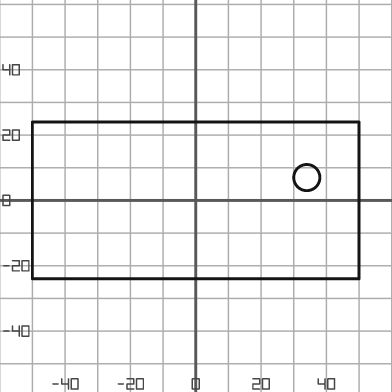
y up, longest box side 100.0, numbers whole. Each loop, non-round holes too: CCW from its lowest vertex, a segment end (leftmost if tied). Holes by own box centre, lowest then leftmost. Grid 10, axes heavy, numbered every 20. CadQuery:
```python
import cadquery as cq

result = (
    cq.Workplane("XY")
    .moveTo(-50.0, -24.0)
    .lineTo(50.0, -24.0)
    .lineTo(50.0, 24.0)
    .lineTo(-50.0, 24.0)
    .close()
    .moveTo(34.0, 7.0)
    .circle(4.0)
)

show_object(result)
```